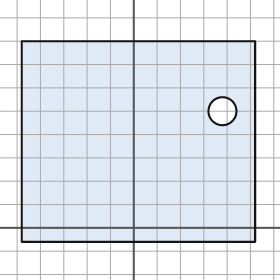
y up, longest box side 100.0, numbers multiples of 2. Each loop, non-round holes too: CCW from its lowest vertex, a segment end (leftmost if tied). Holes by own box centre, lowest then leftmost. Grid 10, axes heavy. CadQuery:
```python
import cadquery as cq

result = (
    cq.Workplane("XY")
    .moveTo(-48.0, -6.0)
    .lineTo(52.0, -6.0)
    .lineTo(52.0, 80.0)
    .lineTo(-48.0, 80.0)
    .close()
    .moveTo(38.0, 50.0)
    .circle(6.0)
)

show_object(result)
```